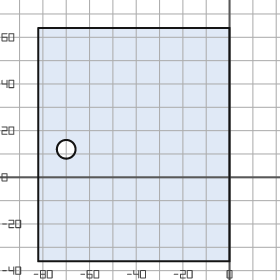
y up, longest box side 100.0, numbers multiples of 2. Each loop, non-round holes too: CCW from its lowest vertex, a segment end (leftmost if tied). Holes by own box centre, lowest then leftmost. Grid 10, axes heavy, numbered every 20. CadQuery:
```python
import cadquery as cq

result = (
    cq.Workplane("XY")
    .moveTo(-82.0, -36.0)
    .lineTo(0.0, -36.0)
    .lineTo(0.0, 64.0)
    .lineTo(-82.0, 64.0)
    .close()
    .moveTo(-70.0, 12.0)
    .circle(4.0)
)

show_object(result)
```